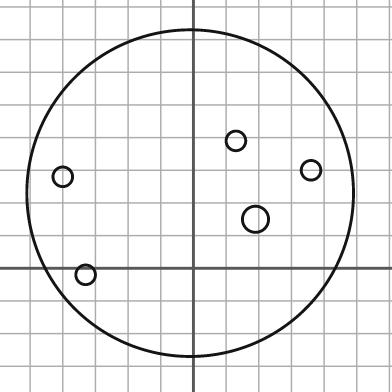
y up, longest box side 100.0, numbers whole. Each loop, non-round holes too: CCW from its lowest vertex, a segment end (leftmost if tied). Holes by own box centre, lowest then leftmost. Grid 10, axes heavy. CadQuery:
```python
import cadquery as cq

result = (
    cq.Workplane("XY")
    .moveTo(-1.0, 23.0)
    .circle(50.0)
    .moveTo(-33.0, -2.0)
    .circle(3.0)
    .moveTo(19.0, 15.0)
    .circle(4.0)
    .moveTo(-40.0, 28.0)
    .circle(3.0)
    .moveTo(36.0, 30.0)
    .circle(3.0)
    .moveTo(13.0, 39.0)
    .circle(3.0)
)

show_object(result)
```